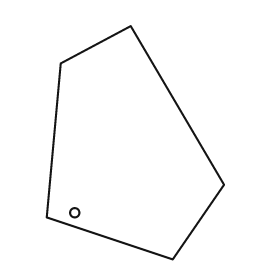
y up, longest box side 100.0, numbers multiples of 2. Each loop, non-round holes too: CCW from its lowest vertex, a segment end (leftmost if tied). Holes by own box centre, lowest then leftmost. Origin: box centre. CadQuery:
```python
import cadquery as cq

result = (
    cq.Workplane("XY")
    .moveTo(16.0, -50.0)
    .lineTo(38.0, -18.0)
    .lineTo(-2.0, 50.0)
    .lineTo(-32.0, 34.0)
    .lineTo(-38.0, -32.0)
    .close()
    .moveTo(-26.0, -30.0)
    .circle(2.0)
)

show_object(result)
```